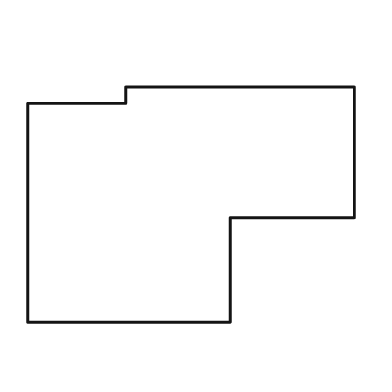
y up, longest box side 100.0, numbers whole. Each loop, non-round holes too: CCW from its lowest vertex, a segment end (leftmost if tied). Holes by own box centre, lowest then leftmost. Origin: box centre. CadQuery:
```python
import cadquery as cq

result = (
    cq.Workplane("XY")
    .moveTo(-50.0, -36.0)
    .lineTo(12.0, -36.0)
    .lineTo(12.0, -4.0)
    .lineTo(50.0, -4.0)
    .lineTo(50.0, 36.0)
    .lineTo(-20.0, 36.0)
    .lineTo(-20.0, 31.0)
    .lineTo(-50.0, 31.0)
    .close()
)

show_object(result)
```